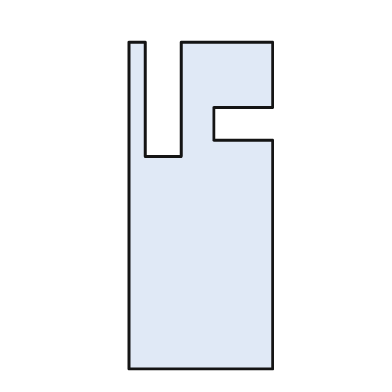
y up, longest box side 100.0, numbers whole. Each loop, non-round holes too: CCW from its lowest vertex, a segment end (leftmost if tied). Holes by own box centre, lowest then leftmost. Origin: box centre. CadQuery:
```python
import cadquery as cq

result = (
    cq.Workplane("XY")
    .moveTo(-22.0, -50.0)
    .lineTo(22.0, -50.0)
    .lineTo(22.0, 20.0)
    .lineTo(4.0, 20.0)
    .lineTo(4.0, 30.0)
    .lineTo(22.0, 30.0)
    .lineTo(22.0, 50.0)
    .lineTo(-6.0, 50.0)
    .lineTo(-6.0, 15.0)
    .lineTo(-17.0, 15.0)
    .lineTo(-17.0, 50.0)
    .lineTo(-22.0, 50.0)
    .close()
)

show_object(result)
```